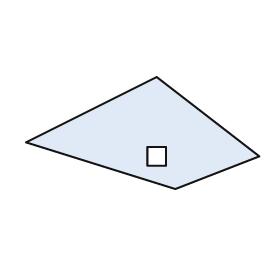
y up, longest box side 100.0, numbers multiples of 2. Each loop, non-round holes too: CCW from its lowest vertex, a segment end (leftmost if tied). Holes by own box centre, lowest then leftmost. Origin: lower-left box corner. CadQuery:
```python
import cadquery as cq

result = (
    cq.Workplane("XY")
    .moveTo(64.0, 0.0)
    .lineTo(100.0, 14.0)
    .lineTo(56.0, 48.0)
    .lineTo(0.0, 20.0)
    .close()
    .moveTo(52.0, 10.0)
    .lineTo(60.0, 10.0)
    .lineTo(60.0, 18.0)
    .lineTo(52.0, 18.0)
    .close()
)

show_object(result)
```